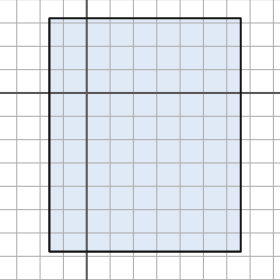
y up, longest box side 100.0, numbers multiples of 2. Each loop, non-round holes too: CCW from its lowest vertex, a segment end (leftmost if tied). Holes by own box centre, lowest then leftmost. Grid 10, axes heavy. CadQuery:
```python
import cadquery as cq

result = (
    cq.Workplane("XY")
    .moveTo(-16.0, -68.0)
    .lineTo(66.0, -68.0)
    .lineTo(66.0, 32.0)
    .lineTo(-16.0, 32.0)
    .close()
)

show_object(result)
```